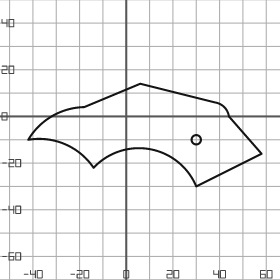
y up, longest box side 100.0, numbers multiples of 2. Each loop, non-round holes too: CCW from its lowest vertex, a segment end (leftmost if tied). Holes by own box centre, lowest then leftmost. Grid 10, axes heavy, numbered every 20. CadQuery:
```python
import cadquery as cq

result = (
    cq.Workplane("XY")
    .moveTo(30.0, -30.0)
    .lineTo(58.0, -16.0)
    .lineTo(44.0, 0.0)
    .threePointArc((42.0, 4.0), (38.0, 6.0))
    .lineTo(6.0, 14.0)
    .lineTo(-18.0, 4.0)
    .threePointArc((-32.0, 0.0), (-42.0, -10.0))
    .threePointArc((-26.0, -12.0), (-14.0, -22.0))
    .threePointArc((10.0, -14.0), (30.0, -30.0))
    .close()
    .moveTo(30.0, -10.0)
    .circle(2.0)
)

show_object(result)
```